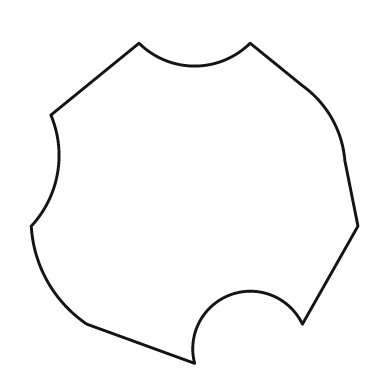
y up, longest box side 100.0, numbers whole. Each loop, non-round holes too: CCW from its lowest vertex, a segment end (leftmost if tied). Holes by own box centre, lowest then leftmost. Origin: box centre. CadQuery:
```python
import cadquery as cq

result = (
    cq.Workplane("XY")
    .moveTo(0.0, -49.0)
    .threePointArc((11.0, -28.0), (33.0, -37.0))
    .lineTo(50.0, -7.0)
    .lineTo(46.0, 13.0)
    .threePointArc((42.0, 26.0), (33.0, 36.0))
    .lineTo(17.0, 49.0)
    .threePointArc((0.0, 42.0), (-17.0, 49.0))
    .lineTo(-44.0, 27.0)
    .threePointArc((-42.0, 9.0), (-50.0, -7.0))
    .threePointArc((-45.0, -24.0), (-33.0, -37.0))
    .close()
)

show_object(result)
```